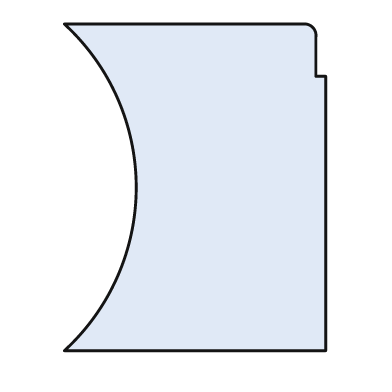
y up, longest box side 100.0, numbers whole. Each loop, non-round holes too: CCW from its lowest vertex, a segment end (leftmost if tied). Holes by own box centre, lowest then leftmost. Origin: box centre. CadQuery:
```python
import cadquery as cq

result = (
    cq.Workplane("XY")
    .moveTo(-40.0, -50.0)
    .lineTo(40.0, -50.0)
    .lineTo(40.0, 34.0)
    .lineTo(37.0, 34.0)
    .lineTo(37.0, 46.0)
    .threePointArc((36.0, 49.0), (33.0, 50.0))
    .lineTo(-40.0, 50.0)
    .threePointArc((-18.0, 0.0), (-40.0, -50.0))
    .close()
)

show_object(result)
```